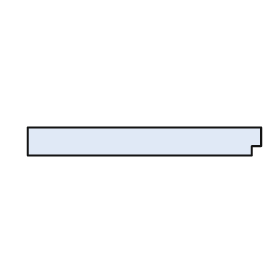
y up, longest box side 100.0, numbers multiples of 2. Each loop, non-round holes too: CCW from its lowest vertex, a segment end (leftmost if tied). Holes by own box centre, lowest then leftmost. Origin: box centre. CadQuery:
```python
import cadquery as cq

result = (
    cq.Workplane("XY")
    .moveTo(-50.0, -6.0)
    .lineTo(46.0, -6.0)
    .lineTo(46.0, -2.0)
    .lineTo(50.0, -2.0)
    .lineTo(50.0, 6.0)
    .lineTo(-50.0, 6.0)
    .close()
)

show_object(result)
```